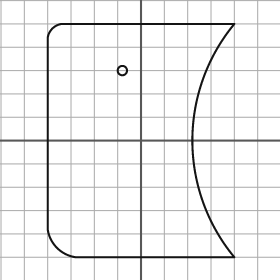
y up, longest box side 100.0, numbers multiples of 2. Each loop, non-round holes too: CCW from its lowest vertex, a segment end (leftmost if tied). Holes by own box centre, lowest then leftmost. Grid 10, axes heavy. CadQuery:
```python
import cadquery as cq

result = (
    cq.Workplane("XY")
    .moveTo(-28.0, -50.0)
    .lineTo(40.0, -50.0)
    .threePointArc((22.0, 0.0), (40.0, 50.0))
    .lineTo(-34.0, 50.0)
    .threePointArc((-38.0, 48.0), (-40.0, 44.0))
    .lineTo(-40.0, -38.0)
    .threePointArc((-36.0, -46.0), (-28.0, -50.0))
    .close()
    .moveTo(-8.0, 30.0)
    .circle(2.0)
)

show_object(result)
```